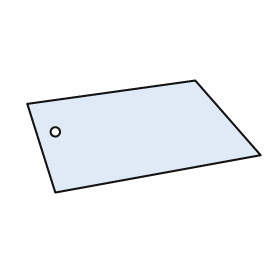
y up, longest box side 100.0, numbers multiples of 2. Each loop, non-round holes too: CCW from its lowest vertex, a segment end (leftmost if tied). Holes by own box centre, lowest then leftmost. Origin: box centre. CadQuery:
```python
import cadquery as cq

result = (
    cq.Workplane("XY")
    .moveTo(-38.0, -24.0)
    .lineTo(50.0, -8.0)
    .lineTo(22.0, 24.0)
    .lineTo(-50.0, 14.0)
    .close()
    .moveTo(-38.0, 2.0)
    .circle(2.0)
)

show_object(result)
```